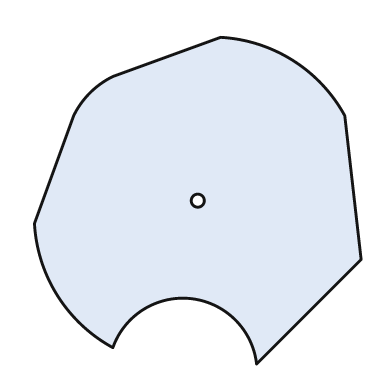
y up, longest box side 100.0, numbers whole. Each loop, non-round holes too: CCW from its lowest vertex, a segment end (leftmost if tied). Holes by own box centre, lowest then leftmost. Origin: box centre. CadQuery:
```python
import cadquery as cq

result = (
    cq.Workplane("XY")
    .moveTo(18.0, -50.0)
    .lineTo(50.0, -18.0)
    .lineTo(45.0, 26.0)
    .threePointArc((29.0, 43.0), (7.0, 50.0))
    .lineTo(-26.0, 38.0)
    .threePointArc((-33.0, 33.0), (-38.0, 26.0))
    .lineTo(-50.0, -7.0)
    .threePointArc((-43.0, -29.0), (-26.0, -45.0))
    .threePointArc((-2.0, -30.0), (18.0, -50.0))
    .close()
    .moveTo(0.0, 0.0)
    .circle(2.0)
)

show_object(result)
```